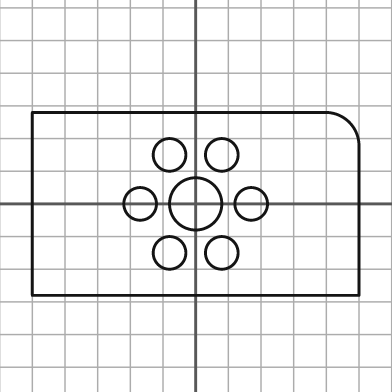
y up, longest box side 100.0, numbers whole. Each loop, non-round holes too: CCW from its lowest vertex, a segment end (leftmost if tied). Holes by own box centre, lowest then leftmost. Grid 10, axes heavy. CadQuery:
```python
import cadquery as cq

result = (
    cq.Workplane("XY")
    .moveTo(-50.0, -28.0)
    .lineTo(50.0, -28.0)
    .lineTo(50.0, 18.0)
    .threePointArc((47.0, 25.0), (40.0, 28.0))
    .lineTo(-50.0, 28.0)
    .close()
    .moveTo(-8.0, -15.0)
    .circle(5.0)
    .moveTo(8.0, -15.0)
    .circle(5.0)
    .moveTo(-17.0, 0.0)
    .circle(5.0)
    .moveTo(0.0, 0.0)
    .circle(8.0)
    .moveTo(17.0, 0.0)
    .circle(5.0)
    .moveTo(-8.0, 15.0)
    .circle(5.0)
    .moveTo(8.0, 15.0)
    .circle(5.0)
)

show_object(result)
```